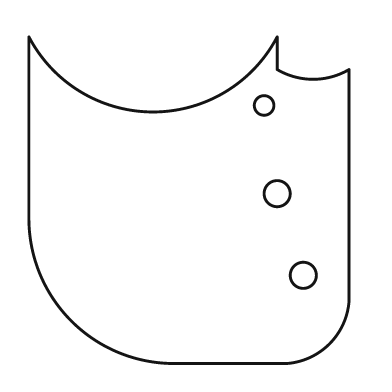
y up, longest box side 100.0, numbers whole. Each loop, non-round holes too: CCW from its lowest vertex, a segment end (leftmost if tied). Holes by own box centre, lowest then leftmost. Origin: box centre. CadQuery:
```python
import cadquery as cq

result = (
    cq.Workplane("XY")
    .moveTo(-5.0, -50.0)
    .lineTo(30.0, -50.0)
    .threePointArc((43.0, -44.0), (49.0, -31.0))
    .lineTo(49.0, 40.0)
    .threePointArc((38.0, 37.0), (27.0, 40.0))
    .lineTo(27.0, 50.0)
    .threePointArc((-11.0, 27.0), (-49.0, 50.0))
    .lineTo(-49.0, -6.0)
    .threePointArc((-36.0, -37.0), (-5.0, -50.0))
    .close()
    .moveTo(35.0, -23.0)
    .circle(4.0)
    .moveTo(27.0, 2.0)
    .circle(4.0)
    .moveTo(23.0, 29.0)
    .circle(3.0)
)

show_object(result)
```